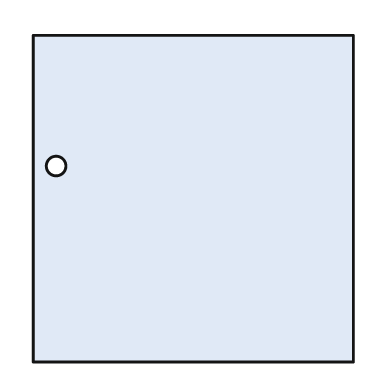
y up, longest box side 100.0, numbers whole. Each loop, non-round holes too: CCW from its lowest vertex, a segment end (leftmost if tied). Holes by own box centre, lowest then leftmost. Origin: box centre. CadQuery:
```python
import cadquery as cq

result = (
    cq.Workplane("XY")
    .moveTo(-49.0, -50.0)
    .lineTo(49.0, -50.0)
    .lineTo(49.0, 50.0)
    .lineTo(-49.0, 50.0)
    .close()
    .moveTo(-42.0, 10.0)
    .circle(3.0)
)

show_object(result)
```